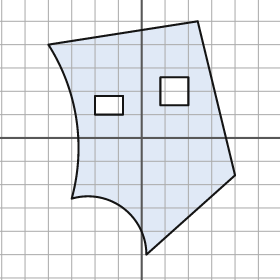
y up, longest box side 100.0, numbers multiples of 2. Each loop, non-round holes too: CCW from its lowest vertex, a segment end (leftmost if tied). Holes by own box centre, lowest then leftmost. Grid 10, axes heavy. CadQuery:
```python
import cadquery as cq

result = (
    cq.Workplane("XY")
    .moveTo(2.0, -50.0)
    .lineTo(40.0, -16.0)
    .lineTo(24.0, 50.0)
    .lineTo(-40.0, 40.0)
    .threePointArc((-28.0, 8.0), (-30.0, -26.0))
    .threePointArc((-8.0, -30.0), (2.0, -50.0))
    .close()
    .moveTo(-20.0, 10.0)
    .lineTo(-8.0, 10.0)
    .lineTo(-8.0, 18.0)
    .lineTo(-20.0, 18.0)
    .close()
    .moveTo(8.0, 14.0)
    .lineTo(20.0, 14.0)
    .lineTo(20.0, 26.0)
    .lineTo(8.0, 26.0)
    .close()
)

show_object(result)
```